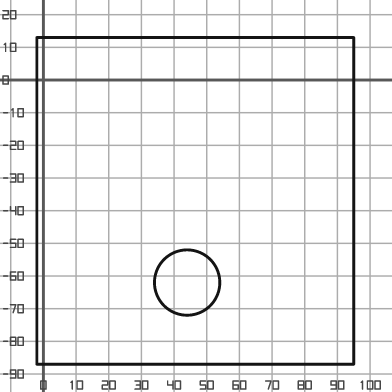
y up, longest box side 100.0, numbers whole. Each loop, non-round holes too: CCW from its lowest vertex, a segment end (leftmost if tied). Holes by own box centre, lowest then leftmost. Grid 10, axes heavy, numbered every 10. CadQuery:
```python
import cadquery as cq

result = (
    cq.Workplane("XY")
    .moveTo(-2.0, -87.0)
    .lineTo(95.0, -87.0)
    .lineTo(95.0, 13.0)
    .lineTo(-2.0, 13.0)
    .close()
    .moveTo(44.0, -62.0)
    .circle(10.0)
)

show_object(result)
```